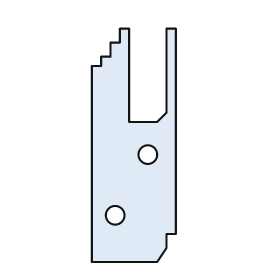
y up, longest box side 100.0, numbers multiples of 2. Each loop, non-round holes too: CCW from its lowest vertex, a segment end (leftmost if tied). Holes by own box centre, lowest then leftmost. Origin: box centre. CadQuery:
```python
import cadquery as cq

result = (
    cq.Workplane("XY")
    .moveTo(-18.0, -50.0)
    .lineTo(10.0, -50.0)
    .lineTo(14.0, -44.0)
    .lineTo(14.0, -38.0)
    .lineTo(18.0, -38.0)
    .lineTo(18.0, 50.0)
    .lineTo(14.0, 50.0)
    .lineTo(14.0, 14.0)
    .lineTo(10.0, 10.0)
    .lineTo(-2.0, 10.0)
    .lineTo(-2.0, 50.0)
    .lineTo(-6.0, 50.0)
    .lineTo(-6.0, 44.0)
    .lineTo(-10.0, 44.0)
    .lineTo(-10.0, 38.0)
    .lineTo(-14.0, 38.0)
    .lineTo(-14.0, 34.0)
    .lineTo(-18.0, 34.0)
    .close()
    .moveTo(-8.0, -30.0)
    .circle(4.0)
    .moveTo(6.0, -4.0)
    .circle(4.0)
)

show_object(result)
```